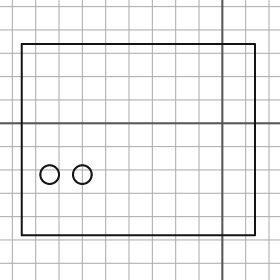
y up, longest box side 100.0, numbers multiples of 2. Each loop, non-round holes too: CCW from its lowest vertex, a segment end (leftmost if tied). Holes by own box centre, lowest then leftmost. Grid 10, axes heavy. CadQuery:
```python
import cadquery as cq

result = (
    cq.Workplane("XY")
    .moveTo(-86.0, -48.0)
    .lineTo(14.0, -48.0)
    .lineTo(14.0, 34.0)
    .lineTo(-86.0, 34.0)
    .close()
    .moveTo(-74.0, -22.0)
    .circle(4.0)
    .moveTo(-60.0, -22.0)
    .circle(4.0)
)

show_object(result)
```